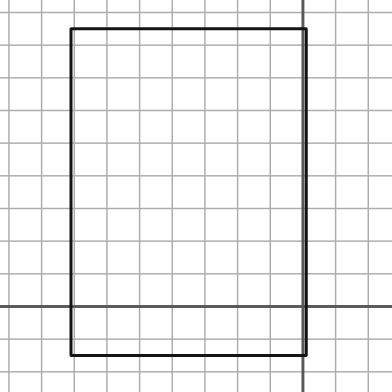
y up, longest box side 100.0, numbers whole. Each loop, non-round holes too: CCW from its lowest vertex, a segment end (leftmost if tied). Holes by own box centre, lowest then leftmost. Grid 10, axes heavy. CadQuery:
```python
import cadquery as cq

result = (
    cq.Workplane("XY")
    .moveTo(-71.0, -15.0)
    .lineTo(1.0, -15.0)
    .lineTo(1.0, 85.0)
    .lineTo(-71.0, 85.0)
    .close()
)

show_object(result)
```